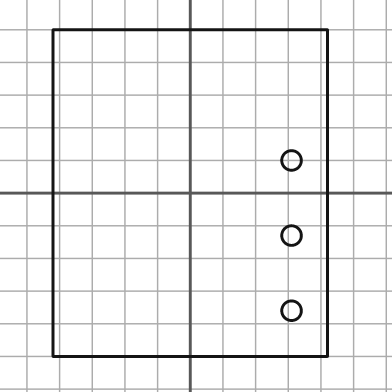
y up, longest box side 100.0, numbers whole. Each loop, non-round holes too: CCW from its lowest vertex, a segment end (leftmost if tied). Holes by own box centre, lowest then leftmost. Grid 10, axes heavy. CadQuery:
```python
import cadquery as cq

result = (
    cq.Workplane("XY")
    .moveTo(-42.0, -50.0)
    .lineTo(42.0, -50.0)
    .lineTo(42.0, 50.0)
    .lineTo(-42.0, 50.0)
    .close()
    .moveTo(31.0, -36.0)
    .circle(3.0)
    .moveTo(31.0, -13.0)
    .circle(3.0)
    .moveTo(31.0, 10.0)
    .circle(3.0)
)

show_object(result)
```